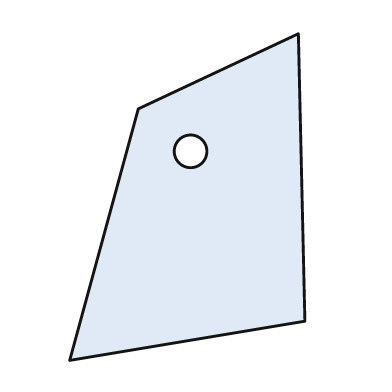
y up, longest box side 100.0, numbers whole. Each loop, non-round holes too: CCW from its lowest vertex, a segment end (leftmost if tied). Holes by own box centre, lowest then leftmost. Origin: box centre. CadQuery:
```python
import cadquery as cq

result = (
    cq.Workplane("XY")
    .moveTo(-36.0, -50.0)
    .lineTo(36.0, -38.0)
    .lineTo(34.0, 50.0)
    .lineTo(-15.0, 27.0)
    .close()
    .moveTo(1.0, 14.0)
    .circle(5.0)
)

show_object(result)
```